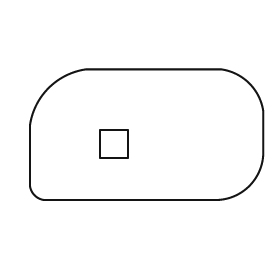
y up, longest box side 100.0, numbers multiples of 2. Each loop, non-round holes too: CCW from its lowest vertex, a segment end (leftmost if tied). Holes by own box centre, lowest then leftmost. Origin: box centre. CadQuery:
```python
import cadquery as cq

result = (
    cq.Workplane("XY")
    .moveTo(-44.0, -28.0)
    .lineTo(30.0, -28.0)
    .threePointArc((44.0, -22.0), (50.0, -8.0))
    .lineTo(50.0, 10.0)
    .threePointArc((44.0, 22.0), (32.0, 28.0))
    .lineTo(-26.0, 28.0)
    .threePointArc((-42.0, 20.0), (-50.0, 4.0))
    .lineTo(-50.0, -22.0)
    .threePointArc((-48.0, -26.0), (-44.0, -28.0))
    .close()
    .moveTo(-20.0, -10.0)
    .lineTo(-8.0, -10.0)
    .lineTo(-8.0, 2.0)
    .lineTo(-20.0, 2.0)
    .close()
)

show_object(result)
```